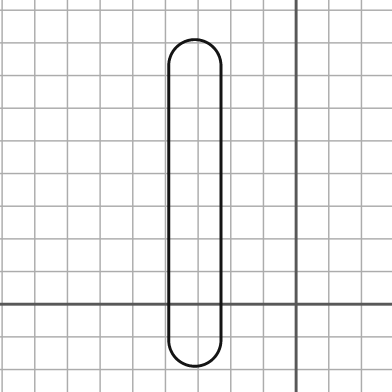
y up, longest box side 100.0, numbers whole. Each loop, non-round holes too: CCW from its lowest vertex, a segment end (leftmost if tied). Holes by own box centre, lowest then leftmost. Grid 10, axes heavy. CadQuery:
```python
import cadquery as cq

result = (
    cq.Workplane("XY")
    .moveTo(-39.0, -11.0)
    .threePointArc((-31.0, -19.0), (-23.0, -11.0))
    .lineTo(-23.0, 73.0)
    .threePointArc((-31.0, 81.0), (-39.0, 73.0))
    .close()
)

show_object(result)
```